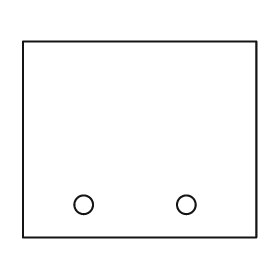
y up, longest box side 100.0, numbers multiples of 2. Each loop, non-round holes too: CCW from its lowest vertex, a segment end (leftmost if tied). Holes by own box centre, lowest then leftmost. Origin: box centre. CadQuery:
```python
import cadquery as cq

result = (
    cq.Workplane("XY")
    .moveTo(-50.0, -42.0)
    .lineTo(50.0, -42.0)
    .lineTo(50.0, 42.0)
    .lineTo(-50.0, 42.0)
    .close()
    .moveTo(-24.0, -28.0)
    .circle(4.0)
    .moveTo(20.0, -28.0)
    .circle(4.0)
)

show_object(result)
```